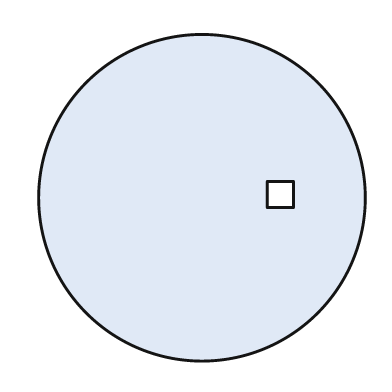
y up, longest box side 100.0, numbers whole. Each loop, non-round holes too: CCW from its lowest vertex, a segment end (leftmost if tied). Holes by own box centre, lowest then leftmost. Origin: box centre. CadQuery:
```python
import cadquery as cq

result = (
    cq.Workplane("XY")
    .moveTo(0.0, 0.0)
    .circle(50.0)
    .moveTo(20.0, -3.0)
    .lineTo(28.0, -3.0)
    .lineTo(28.0, 5.0)
    .lineTo(20.0, 5.0)
    .close()
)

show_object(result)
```